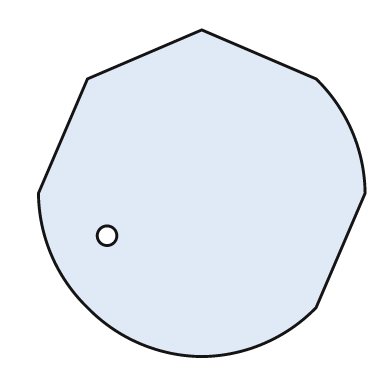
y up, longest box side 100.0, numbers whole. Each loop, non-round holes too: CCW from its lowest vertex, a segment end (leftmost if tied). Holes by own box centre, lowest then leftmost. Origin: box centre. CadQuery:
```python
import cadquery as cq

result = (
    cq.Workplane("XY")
    .moveTo(0.0, -50.0)
    .threePointArc((19.0, -46.0), (35.0, -35.0))
    .lineTo(50.0, 0.0)
    .threePointArc((46.0, 19.0), (35.0, 35.0))
    .lineTo(0.0, 50.0)
    .lineTo(-35.0, 35.0)
    .lineTo(-50.0, 0.0)
    .threePointArc((-46.0, -19.0), (-35.0, -35.0))
    .threePointArc((-19.0, -46.0), (0.0, -50.0))
    .close()
    .moveTo(-29.0, -13.0)
    .circle(3.0)
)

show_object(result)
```